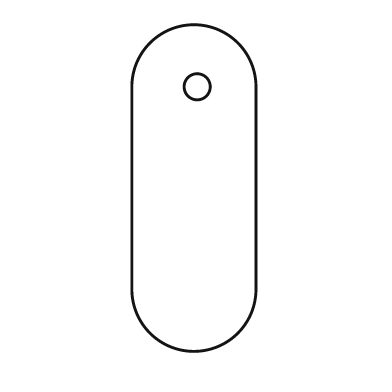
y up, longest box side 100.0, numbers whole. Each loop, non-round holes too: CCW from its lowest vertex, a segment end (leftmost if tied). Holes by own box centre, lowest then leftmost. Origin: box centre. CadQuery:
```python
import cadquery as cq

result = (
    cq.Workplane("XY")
    .moveTo(-19.0, -31.0)
    .threePointArc((0.0, -50.0), (19.0, -31.0))
    .lineTo(19.0, 31.0)
    .threePointArc((0.0, 50.0), (-19.0, 31.0))
    .close()
    .moveTo(1.0, 31.0)
    .circle(4.0)
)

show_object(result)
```